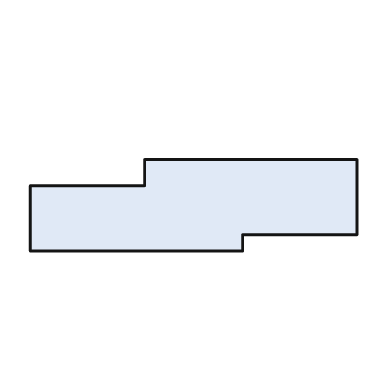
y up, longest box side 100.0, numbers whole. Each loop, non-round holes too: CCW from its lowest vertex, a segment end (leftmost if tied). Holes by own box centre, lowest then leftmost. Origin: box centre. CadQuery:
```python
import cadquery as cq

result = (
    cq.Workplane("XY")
    .moveTo(-50.0, -14.0)
    .lineTo(15.0, -14.0)
    .lineTo(15.0, -9.0)
    .lineTo(50.0, -9.0)
    .lineTo(50.0, 14.0)
    .lineTo(-15.0, 14.0)
    .lineTo(-15.0, 6.0)
    .lineTo(-50.0, 6.0)
    .close()
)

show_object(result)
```